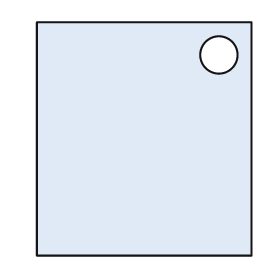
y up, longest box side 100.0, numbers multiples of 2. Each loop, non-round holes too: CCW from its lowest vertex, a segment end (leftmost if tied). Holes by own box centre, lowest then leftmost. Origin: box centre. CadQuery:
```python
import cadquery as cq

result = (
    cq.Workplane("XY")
    .moveTo(-46.0, -50.0)
    .lineTo(46.0, -50.0)
    .lineTo(46.0, 50.0)
    .lineTo(-46.0, 50.0)
    .close()
    .moveTo(32.0, 36.0)
    .circle(8.0)
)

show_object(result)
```